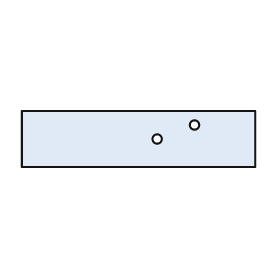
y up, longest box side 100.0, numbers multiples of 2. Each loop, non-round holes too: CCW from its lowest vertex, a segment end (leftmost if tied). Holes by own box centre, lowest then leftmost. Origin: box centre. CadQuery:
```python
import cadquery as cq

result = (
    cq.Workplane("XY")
    .moveTo(-50.0, -12.0)
    .lineTo(50.0, -12.0)
    .lineTo(50.0, 12.0)
    .lineTo(-50.0, 12.0)
    .close()
    .moveTo(8.0, 0.0)
    .circle(2.0)
    .moveTo(24.0, 6.0)
    .circle(2.0)
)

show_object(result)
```